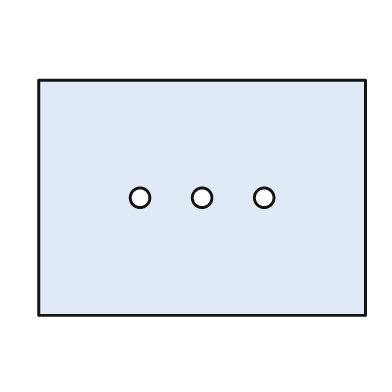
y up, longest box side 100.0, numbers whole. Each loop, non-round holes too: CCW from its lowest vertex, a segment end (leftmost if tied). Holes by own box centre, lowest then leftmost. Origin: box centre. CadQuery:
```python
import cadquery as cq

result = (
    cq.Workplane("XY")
    .moveTo(-50.0, -36.0)
    .lineTo(50.0, -36.0)
    .lineTo(50.0, 36.0)
    .lineTo(-50.0, 36.0)
    .close()
    .moveTo(-19.0, 0.0)
    .circle(3.0)
    .moveTo(0.0, 0.0)
    .circle(3.0)
    .moveTo(19.0, 0.0)
    .circle(3.0)
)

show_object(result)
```